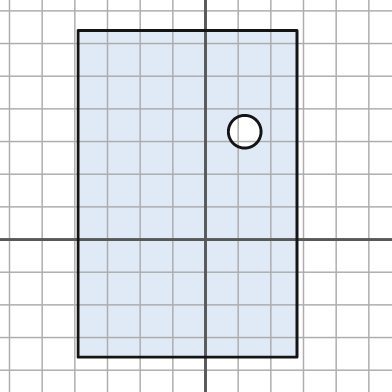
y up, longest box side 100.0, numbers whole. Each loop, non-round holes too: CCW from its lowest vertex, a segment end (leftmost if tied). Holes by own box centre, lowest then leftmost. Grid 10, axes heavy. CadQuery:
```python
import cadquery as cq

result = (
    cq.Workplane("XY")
    .moveTo(-39.0, -36.0)
    .lineTo(28.0, -36.0)
    .lineTo(28.0, 64.0)
    .lineTo(-39.0, 64.0)
    .close()
    .moveTo(12.0, 33.0)
    .circle(5.0)
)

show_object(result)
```